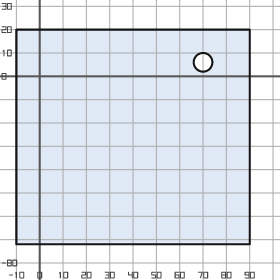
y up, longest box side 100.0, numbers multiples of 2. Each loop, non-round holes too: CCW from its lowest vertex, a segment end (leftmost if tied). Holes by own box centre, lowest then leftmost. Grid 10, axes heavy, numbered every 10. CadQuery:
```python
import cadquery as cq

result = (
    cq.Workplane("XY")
    .moveTo(-10.0, -72.0)
    .lineTo(90.0, -72.0)
    .lineTo(90.0, 20.0)
    .lineTo(-10.0, 20.0)
    .close()
    .moveTo(70.0, 6.0)
    .circle(4.0)
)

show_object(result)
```